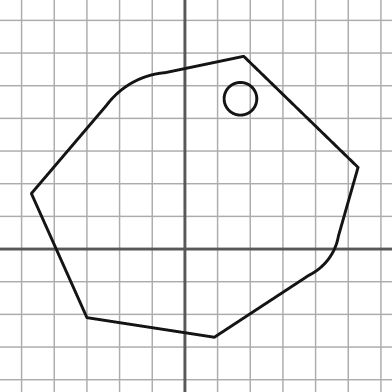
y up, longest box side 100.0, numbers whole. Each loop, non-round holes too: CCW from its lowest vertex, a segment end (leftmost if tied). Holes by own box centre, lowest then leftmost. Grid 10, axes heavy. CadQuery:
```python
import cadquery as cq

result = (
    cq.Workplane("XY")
    .moveTo(9.0, -27.0)
    .lineTo(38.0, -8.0)
    .threePointArc((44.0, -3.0), (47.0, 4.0))
    .lineTo(53.0, 25.0)
    .lineTo(18.0, 59.0)
    .lineTo(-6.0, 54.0)
    .threePointArc((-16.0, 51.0), (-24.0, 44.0))
    .lineTo(-47.0, 17.0)
    .lineTo(-30.0, -21.0)
    .close()
    .moveTo(17.0, 46.0)
    .circle(5.0)
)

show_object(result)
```